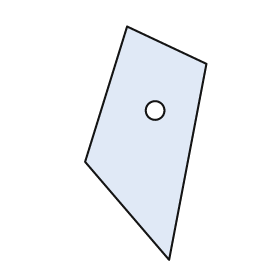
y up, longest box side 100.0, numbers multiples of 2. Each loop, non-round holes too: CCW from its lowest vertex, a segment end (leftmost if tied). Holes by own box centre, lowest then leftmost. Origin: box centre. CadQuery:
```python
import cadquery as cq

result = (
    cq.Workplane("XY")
    .moveTo(10.0, -50.0)
    .lineTo(26.0, 34.0)
    .lineTo(-8.0, 50.0)
    .lineTo(-26.0, -8.0)
    .close()
    .moveTo(4.0, 14.0)
    .circle(4.0)
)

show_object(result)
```